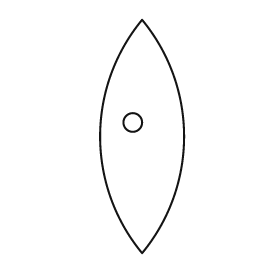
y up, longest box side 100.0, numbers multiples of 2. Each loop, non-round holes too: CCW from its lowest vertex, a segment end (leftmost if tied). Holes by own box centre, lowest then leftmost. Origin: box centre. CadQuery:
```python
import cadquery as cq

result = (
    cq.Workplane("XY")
    .moveTo(0.0, -50.0)
    .threePointArc((18.0, 0.0), (0.0, 50.0))
    .threePointArc((-18.0, 0.0), (0.0, -50.0))
    .close()
    .moveTo(-4.0, 6.0)
    .circle(4.0)
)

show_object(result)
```